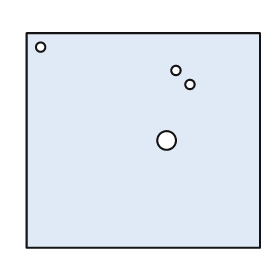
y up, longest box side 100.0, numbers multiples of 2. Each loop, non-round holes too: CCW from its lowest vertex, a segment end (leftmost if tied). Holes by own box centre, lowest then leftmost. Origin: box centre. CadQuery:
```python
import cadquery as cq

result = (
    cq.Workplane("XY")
    .moveTo(-50.0, -46.0)
    .lineTo(50.0, -46.0)
    .lineTo(50.0, 46.0)
    .lineTo(-50.0, 46.0)
    .close()
    .moveTo(10.0, 0.0)
    .circle(4.0)
    .moveTo(20.0, 24.0)
    .circle(2.0)
    .moveTo(14.0, 30.0)
    .circle(2.0)
    .moveTo(-44.0, 40.0)
    .circle(2.0)
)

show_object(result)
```